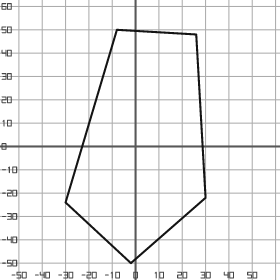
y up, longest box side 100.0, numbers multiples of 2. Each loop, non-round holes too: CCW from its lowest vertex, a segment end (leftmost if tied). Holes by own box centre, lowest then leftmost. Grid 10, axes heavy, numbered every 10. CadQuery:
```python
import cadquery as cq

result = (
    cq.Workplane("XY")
    .moveTo(-2.0, -50.0)
    .lineTo(30.0, -22.0)
    .lineTo(26.0, 48.0)
    .lineTo(-8.0, 50.0)
    .lineTo(-30.0, -24.0)
    .close()
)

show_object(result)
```